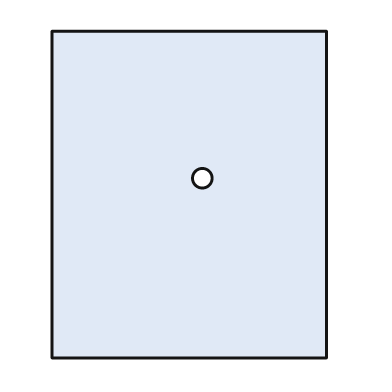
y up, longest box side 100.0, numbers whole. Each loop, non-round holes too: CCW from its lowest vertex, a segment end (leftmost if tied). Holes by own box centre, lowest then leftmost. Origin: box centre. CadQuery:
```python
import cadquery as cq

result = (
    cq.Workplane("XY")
    .moveTo(-42.0, -50.0)
    .lineTo(42.0, -50.0)
    .lineTo(42.0, 50.0)
    .lineTo(-42.0, 50.0)
    .close()
    .moveTo(4.0, 5.0)
    .circle(3.0)
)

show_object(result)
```